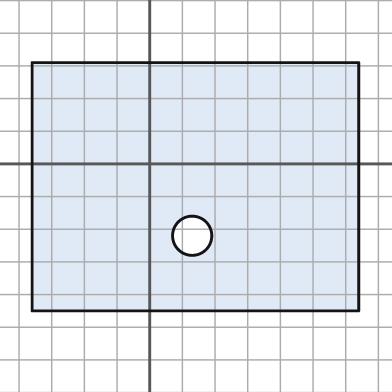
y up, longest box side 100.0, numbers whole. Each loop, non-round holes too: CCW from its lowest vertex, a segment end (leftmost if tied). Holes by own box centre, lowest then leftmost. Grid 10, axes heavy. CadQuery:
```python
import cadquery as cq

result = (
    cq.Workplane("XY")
    .moveTo(-36.0, -45.0)
    .lineTo(64.0, -45.0)
    .lineTo(64.0, 31.0)
    .lineTo(-36.0, 31.0)
    .close()
    .moveTo(13.0, -22.0)
    .circle(6.0)
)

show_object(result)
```